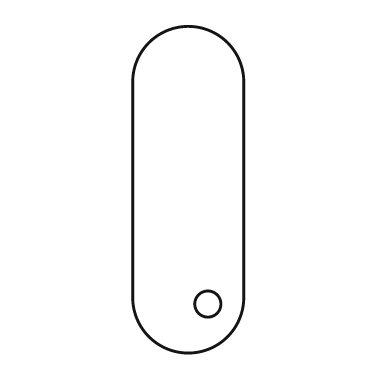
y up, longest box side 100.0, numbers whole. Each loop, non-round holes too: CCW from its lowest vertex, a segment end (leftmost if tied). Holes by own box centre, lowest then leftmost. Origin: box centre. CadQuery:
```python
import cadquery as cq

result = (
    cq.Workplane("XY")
    .moveTo(-17.0, -33.0)
    .threePointArc((0.0, -50.0), (17.0, -33.0))
    .lineTo(17.0, 33.0)
    .threePointArc((0.0, 50.0), (-17.0, 33.0))
    .close()
    .moveTo(6.0, -35.0)
    .circle(4.0)
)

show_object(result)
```